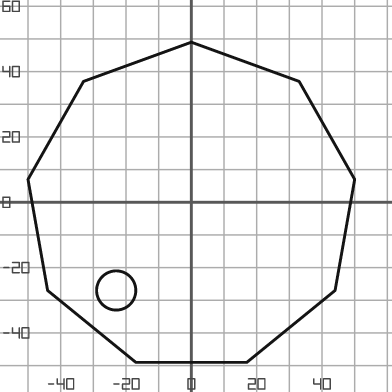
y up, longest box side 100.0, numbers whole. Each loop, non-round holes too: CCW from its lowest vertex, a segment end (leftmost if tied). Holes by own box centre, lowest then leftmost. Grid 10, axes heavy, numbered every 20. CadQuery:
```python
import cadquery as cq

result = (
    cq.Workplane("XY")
    .moveTo(-17.0, -49.0)
    .lineTo(17.0, -49.0)
    .lineTo(44.0, -27.0)
    .lineTo(50.0, 7.0)
    .lineTo(33.0, 37.0)
    .lineTo(0.0, 49.0)
    .lineTo(-33.0, 37.0)
    .lineTo(-50.0, 7.0)
    .lineTo(-44.0, -27.0)
    .close()
    .moveTo(-23.0, -27.0)
    .circle(6.0)
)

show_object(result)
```